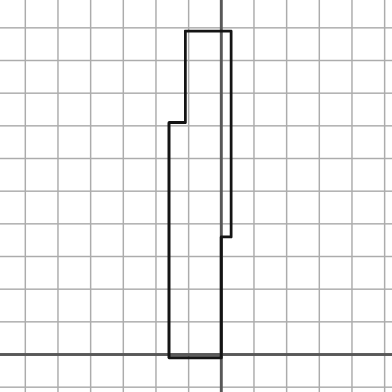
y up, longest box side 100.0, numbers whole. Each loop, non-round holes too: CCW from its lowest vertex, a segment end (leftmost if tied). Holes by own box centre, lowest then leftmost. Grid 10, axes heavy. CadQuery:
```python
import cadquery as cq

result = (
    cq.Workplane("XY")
    .moveTo(-16.0, -1.0)
    .lineTo(0.0, -1.0)
    .lineTo(0.0, 36.0)
    .lineTo(3.0, 36.0)
    .lineTo(3.0, 99.0)
    .lineTo(-11.0, 99.0)
    .lineTo(-11.0, 71.0)
    .lineTo(-16.0, 71.0)
    .close()
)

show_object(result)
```